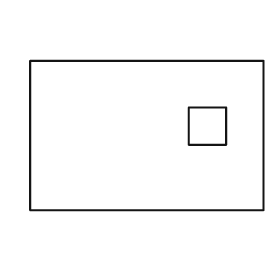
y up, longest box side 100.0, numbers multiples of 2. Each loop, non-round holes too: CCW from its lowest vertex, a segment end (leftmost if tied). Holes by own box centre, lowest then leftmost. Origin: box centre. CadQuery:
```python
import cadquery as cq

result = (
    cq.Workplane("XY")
    .moveTo(-50.0, -32.0)
    .lineTo(50.0, -32.0)
    .lineTo(50.0, 32.0)
    .lineTo(-50.0, 32.0)
    .close()
    .moveTo(18.0, -4.0)
    .lineTo(34.0, -4.0)
    .lineTo(34.0, 12.0)
    .lineTo(18.0, 12.0)
    .close()
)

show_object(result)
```